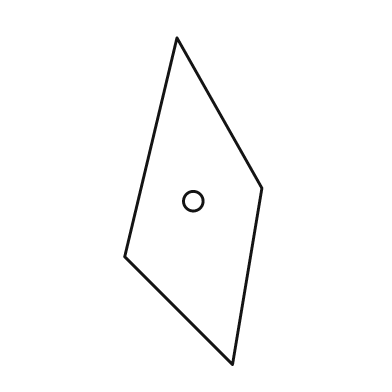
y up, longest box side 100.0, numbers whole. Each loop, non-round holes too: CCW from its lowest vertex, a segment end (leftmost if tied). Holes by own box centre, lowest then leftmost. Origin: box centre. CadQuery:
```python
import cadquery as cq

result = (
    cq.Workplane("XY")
    .moveTo(12.0, -50.0)
    .lineTo(21.0, 4.0)
    .lineTo(-5.0, 50.0)
    .lineTo(-21.0, -17.0)
    .close()
    .moveTo(0.0, 0.0)
    .circle(3.0)
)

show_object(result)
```